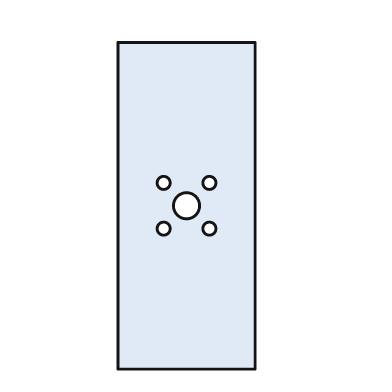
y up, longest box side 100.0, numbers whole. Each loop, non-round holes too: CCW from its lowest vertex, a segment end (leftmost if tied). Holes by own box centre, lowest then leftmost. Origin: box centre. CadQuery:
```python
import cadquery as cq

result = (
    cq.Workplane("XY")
    .moveTo(-21.0, -50.0)
    .lineTo(21.0, -50.0)
    .lineTo(21.0, 50.0)
    .lineTo(-21.0, 50.0)
    .close()
    .moveTo(-7.0, -7.0)
    .circle(2.0)
    .moveTo(7.0, -7.0)
    .circle(2.0)
    .moveTo(0.0, 0.0)
    .circle(4.0)
    .moveTo(-7.0, 7.0)
    .circle(2.0)
    .moveTo(7.0, 7.0)
    .circle(2.0)
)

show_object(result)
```